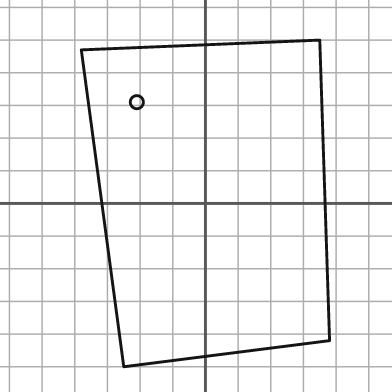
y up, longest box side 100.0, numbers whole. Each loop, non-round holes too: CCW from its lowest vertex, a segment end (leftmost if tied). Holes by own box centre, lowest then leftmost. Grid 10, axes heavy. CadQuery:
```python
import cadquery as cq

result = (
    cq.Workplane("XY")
    .moveTo(-25.0, -50.0)
    .lineTo(38.0, -42.0)
    .lineTo(35.0, 50.0)
    .lineTo(-38.0, 47.0)
    .close()
    .moveTo(-21.0, 31.0)
    .circle(2.0)
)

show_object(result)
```